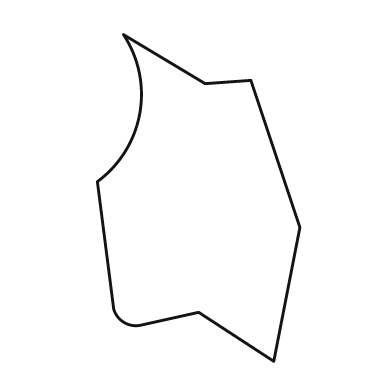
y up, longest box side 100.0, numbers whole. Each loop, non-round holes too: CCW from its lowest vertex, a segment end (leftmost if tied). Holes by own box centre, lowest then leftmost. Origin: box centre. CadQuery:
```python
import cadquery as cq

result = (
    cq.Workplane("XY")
    .moveTo(23.0, -50.0)
    .lineTo(31.0, -9.0)
    .lineTo(16.0, 36.0)
    .lineTo(2.0, 35.0)
    .lineTo(-23.0, 50.0)
    .threePointArc((-18.0, 26.0), (-31.0, 5.0))
    .lineTo(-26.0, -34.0)
    .threePointArc((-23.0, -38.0), (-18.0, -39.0))
    .lineTo(0.0, -35.0)
    .close()
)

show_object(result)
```